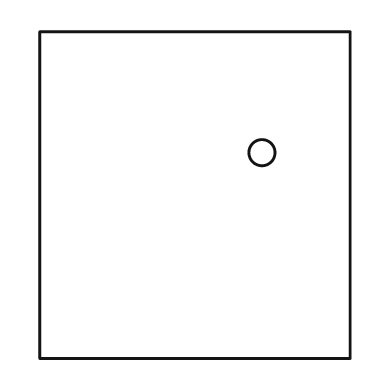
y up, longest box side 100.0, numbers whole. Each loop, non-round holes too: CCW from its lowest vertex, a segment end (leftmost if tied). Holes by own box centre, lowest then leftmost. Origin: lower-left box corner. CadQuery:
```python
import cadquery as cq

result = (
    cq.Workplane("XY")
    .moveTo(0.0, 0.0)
    .lineTo(95.0, 0.0)
    .lineTo(95.0, 100.0)
    .lineTo(0.0, 100.0)
    .close()
    .moveTo(68.0, 63.0)
    .circle(4.0)
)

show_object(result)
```